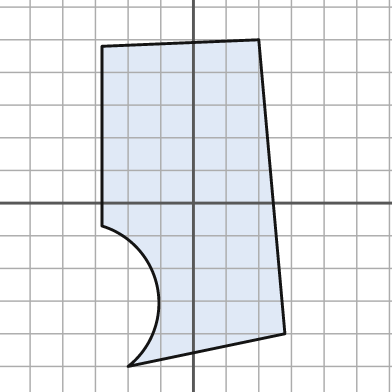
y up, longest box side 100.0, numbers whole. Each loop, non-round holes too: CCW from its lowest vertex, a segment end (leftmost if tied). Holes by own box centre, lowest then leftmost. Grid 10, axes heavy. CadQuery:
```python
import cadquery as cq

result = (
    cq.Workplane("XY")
    .moveTo(-20.0, -50.0)
    .lineTo(28.0, -40.0)
    .lineTo(20.0, 50.0)
    .lineTo(-28.0, 48.0)
    .lineTo(-28.0, -7.0)
    .threePointArc((-11.0, -26.0), (-20.0, -50.0))
    .close()
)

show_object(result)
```